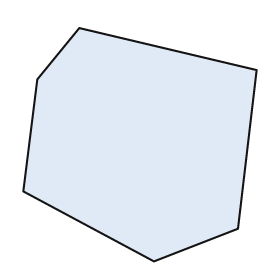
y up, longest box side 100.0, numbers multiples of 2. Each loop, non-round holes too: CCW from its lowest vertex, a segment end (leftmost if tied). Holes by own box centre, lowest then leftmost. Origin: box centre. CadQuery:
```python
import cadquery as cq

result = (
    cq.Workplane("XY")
    .moveTo(6.0, -50.0)
    .lineTo(42.0, -36.0)
    .lineTo(50.0, 32.0)
    .lineTo(-26.0, 50.0)
    .lineTo(-44.0, 28.0)
    .lineTo(-50.0, -20.0)
    .close()
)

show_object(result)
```